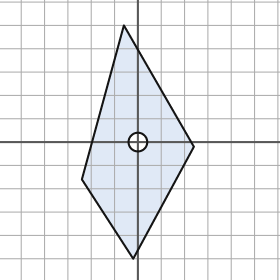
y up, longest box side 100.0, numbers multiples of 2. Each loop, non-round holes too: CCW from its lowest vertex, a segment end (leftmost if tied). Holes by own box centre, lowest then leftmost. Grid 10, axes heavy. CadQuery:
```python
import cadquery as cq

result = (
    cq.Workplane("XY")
    .moveTo(-2.0, -50.0)
    .lineTo(24.0, -2.0)
    .lineTo(-6.0, 50.0)
    .lineTo(-24.0, -16.0)
    .close()
    .moveTo(0.0, 0.0)
    .circle(4.0)
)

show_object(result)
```